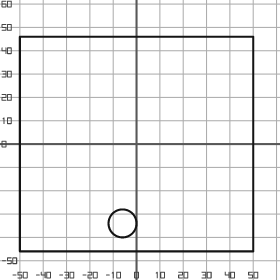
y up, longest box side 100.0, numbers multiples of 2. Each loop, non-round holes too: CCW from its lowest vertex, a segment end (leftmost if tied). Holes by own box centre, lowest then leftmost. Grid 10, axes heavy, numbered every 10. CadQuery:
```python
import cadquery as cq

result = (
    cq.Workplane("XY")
    .moveTo(-50.0, -46.0)
    .lineTo(50.0, -46.0)
    .lineTo(50.0, 46.0)
    .lineTo(-50.0, 46.0)
    .close()
    .moveTo(-6.0, -34.0)
    .circle(6.0)
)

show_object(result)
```